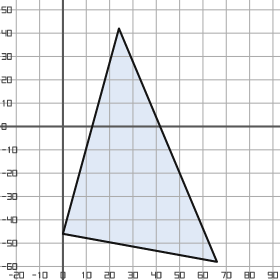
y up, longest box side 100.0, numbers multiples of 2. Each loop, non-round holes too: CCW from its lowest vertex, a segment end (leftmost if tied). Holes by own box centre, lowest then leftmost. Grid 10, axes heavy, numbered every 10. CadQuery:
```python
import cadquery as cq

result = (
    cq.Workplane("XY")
    .moveTo(66.0, -58.0)
    .lineTo(24.0, 42.0)
    .lineTo(0.0, -46.0)
    .close()
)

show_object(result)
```